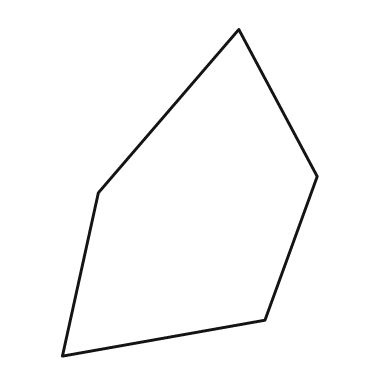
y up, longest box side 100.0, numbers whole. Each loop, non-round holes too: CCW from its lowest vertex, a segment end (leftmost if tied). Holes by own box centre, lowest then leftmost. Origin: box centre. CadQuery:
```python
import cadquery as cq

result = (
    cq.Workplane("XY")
    .moveTo(-39.0, -50.0)
    .lineTo(23.0, -39.0)
    .lineTo(39.0, 5.0)
    .lineTo(15.0, 50.0)
    .lineTo(-28.0, 0.0)
    .close()
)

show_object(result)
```